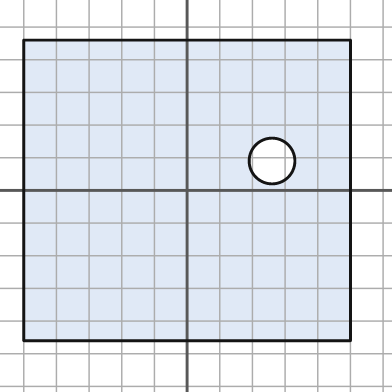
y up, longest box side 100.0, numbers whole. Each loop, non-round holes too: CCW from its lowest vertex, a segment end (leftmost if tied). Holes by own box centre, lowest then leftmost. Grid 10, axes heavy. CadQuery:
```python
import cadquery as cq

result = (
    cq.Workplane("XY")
    .moveTo(-50.0, -46.0)
    .lineTo(50.0, -46.0)
    .lineTo(50.0, 46.0)
    .lineTo(-50.0, 46.0)
    .close()
    .moveTo(26.0, 9.0)
    .circle(7.0)
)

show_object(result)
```